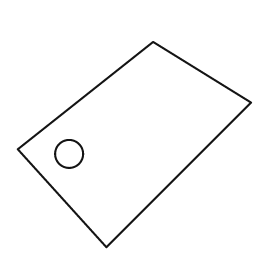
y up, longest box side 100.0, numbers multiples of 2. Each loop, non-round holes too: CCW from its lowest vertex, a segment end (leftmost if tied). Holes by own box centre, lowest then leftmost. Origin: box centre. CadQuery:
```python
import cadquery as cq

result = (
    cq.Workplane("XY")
    .moveTo(-12.0, -44.0)
    .lineTo(50.0, 18.0)
    .lineTo(8.0, 44.0)
    .lineTo(-50.0, -2.0)
    .close()
    .moveTo(-28.0, -4.0)
    .circle(6.0)
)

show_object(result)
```